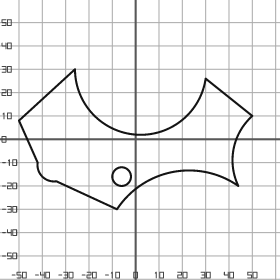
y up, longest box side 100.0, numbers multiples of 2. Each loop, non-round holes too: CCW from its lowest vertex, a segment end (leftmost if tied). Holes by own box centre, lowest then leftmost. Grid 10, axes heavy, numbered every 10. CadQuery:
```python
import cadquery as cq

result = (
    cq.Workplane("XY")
    .moveTo(-8.0, -30.0)
    .threePointArc((16.0, -14.0), (44.0, -20.0))
    .threePointArc((42.0, -4.0), (50.0, 10.0))
    .lineTo(30.0, 26.0)
    .threePointArc((0.0, 2.0), (-26.0, 30.0))
    .lineTo(-50.0, 8.0)
    .lineTo(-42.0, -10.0)
    .threePointArc((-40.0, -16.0), (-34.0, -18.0))
    .close()
    .moveTo(-6.0, -16.0)
    .circle(4.0)
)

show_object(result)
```